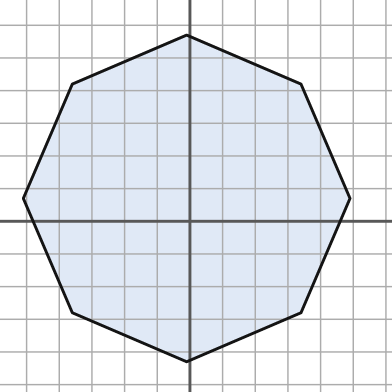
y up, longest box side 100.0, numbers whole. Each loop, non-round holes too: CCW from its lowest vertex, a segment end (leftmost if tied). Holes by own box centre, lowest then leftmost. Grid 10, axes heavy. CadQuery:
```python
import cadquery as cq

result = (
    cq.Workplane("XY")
    .moveTo(-1.0, -43.0)
    .lineTo(34.0, -28.0)
    .lineTo(49.0, 7.0)
    .lineTo(34.0, 42.0)
    .lineTo(-1.0, 57.0)
    .lineTo(-36.0, 42.0)
    .lineTo(-51.0, 7.0)
    .lineTo(-36.0, -28.0)
    .close()
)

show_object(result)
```